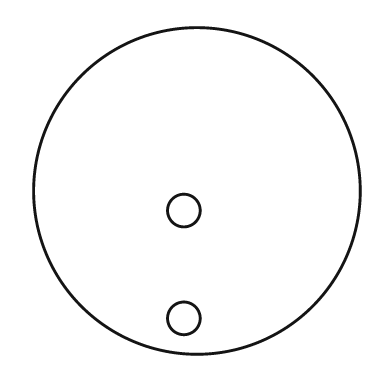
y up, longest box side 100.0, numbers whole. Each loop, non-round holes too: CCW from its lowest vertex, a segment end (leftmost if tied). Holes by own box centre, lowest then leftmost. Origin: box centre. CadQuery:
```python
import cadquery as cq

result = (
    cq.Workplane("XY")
    .moveTo(0.0, 0.0)
    .circle(50.0)
    .moveTo(-4.0, -39.0)
    .circle(5.0)
    .moveTo(-4.0, -6.0)
    .circle(5.0)
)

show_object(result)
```